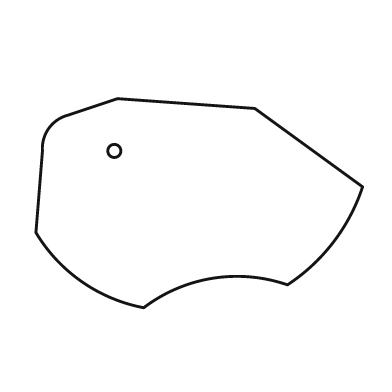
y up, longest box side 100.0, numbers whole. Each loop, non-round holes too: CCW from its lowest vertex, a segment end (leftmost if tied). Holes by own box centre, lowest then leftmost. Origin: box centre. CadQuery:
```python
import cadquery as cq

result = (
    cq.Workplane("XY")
    .moveTo(-17.0, -32.0)
    .threePointArc((4.0, -23.0), (27.0, -25.0))
    .threePointArc((41.0, -12.0), (50.0, 5.0))
    .lineTo(17.0, 29.0)
    .lineTo(-25.0, 32.0)
    .lineTo(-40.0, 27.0)
    .threePointArc((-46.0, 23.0), (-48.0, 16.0))
    .lineTo(-50.0, -9.0)
    .threePointArc((-36.0, -24.0), (-17.0, -32.0))
    .close()
    .moveTo(-26.0, 16.0)
    .circle(2.0)
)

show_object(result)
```